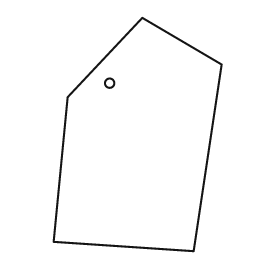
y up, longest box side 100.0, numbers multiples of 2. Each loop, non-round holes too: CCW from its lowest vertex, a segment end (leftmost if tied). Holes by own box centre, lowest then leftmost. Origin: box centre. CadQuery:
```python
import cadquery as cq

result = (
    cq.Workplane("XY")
    .moveTo(24.0, -50.0)
    .lineTo(36.0, 30.0)
    .lineTo(2.0, 50.0)
    .lineTo(-30.0, 16.0)
    .lineTo(-36.0, -46.0)
    .close()
    .moveTo(-12.0, 22.0)
    .circle(2.0)
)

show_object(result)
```